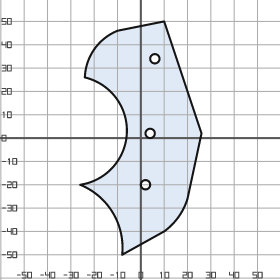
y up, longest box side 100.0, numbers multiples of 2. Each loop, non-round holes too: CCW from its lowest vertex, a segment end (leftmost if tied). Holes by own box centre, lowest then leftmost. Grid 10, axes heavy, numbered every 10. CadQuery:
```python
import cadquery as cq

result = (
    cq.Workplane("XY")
    .moveTo(-8.0, -50.0)
    .lineTo(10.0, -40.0)
    .threePointArc((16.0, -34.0), (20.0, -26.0))
    .lineTo(26.0, 2.0)
    .lineTo(10.0, 50.0)
    .lineTo(-10.0, 46.0)
    .threePointArc((-20.0, 38.0), (-24.0, 26.0))
    .threePointArc((-6.0, 2.0), (-26.0, -20.0))
    .threePointArc((-12.0, -32.0), (-8.0, -50.0))
    .close()
    .moveTo(2.0, -20.0)
    .circle(2.0)
    .moveTo(4.0, 2.0)
    .circle(2.0)
    .moveTo(6.0, 34.0)
    .circle(2.0)
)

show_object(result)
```